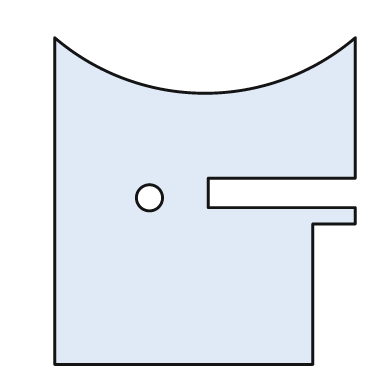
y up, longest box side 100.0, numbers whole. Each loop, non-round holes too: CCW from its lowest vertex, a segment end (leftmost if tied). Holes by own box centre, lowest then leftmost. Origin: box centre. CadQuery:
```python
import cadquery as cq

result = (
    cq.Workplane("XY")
    .moveTo(-46.0, -50.0)
    .lineTo(33.0, -50.0)
    .lineTo(33.0, -7.0)
    .lineTo(46.0, -7.0)
    .lineTo(46.0, -2.0)
    .lineTo(1.0, -2.0)
    .lineTo(1.0, 7.0)
    .lineTo(46.0, 7.0)
    .lineTo(46.0, 50.0)
    .threePointArc((0.0, 33.0), (-46.0, 50.0))
    .close()
    .moveTo(-17.0, 1.0)
    .circle(4.0)
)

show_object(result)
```